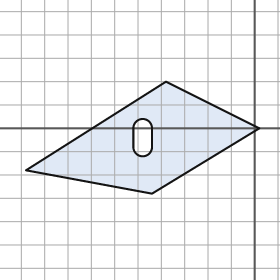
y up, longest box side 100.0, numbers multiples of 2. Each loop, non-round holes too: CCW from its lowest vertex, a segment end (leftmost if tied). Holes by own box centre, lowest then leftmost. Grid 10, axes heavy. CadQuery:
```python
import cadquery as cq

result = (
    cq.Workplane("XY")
    .moveTo(-44.0, -28.0)
    .lineTo(2.0, 0.0)
    .lineTo(-38.0, 20.0)
    .lineTo(-98.0, -18.0)
    .close()
    .moveTo(-52.0, -8.0)
    .threePointArc((-48.0, -12.0), (-44.0, -8.0))
    .lineTo(-44.0, 0.0)
    .threePointArc((-48.0, 4.0), (-52.0, 0.0))
    .close()
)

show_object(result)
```